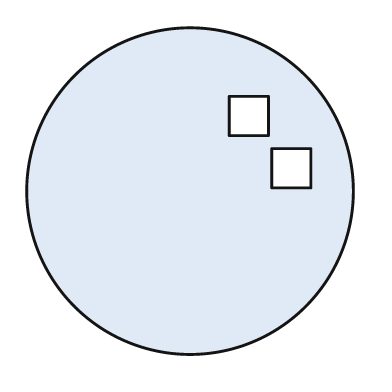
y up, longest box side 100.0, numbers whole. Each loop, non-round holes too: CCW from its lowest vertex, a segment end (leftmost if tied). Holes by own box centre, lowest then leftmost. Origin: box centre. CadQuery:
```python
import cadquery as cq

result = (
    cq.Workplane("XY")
    .moveTo(0.0, 0.0)
    .circle(50.0)
    .moveTo(25.0, 1.0)
    .lineTo(37.0, 1.0)
    .lineTo(37.0, 13.0)
    .lineTo(25.0, 13.0)
    .close()
    .moveTo(12.0, 17.0)
    .lineTo(24.0, 17.0)
    .lineTo(24.0, 29.0)
    .lineTo(12.0, 29.0)
    .close()
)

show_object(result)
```